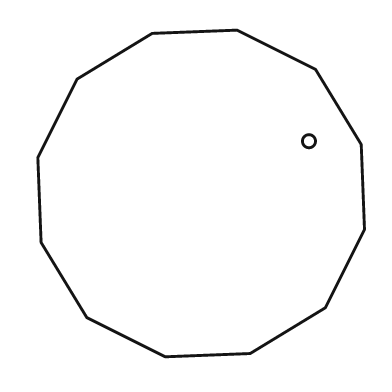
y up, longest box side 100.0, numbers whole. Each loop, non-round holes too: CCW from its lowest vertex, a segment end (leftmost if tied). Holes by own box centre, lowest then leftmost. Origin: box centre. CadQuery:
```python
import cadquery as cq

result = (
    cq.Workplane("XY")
    .moveTo(-11.0, -50.0)
    .lineTo(15.0, -49.0)
    .lineTo(38.0, -35.0)
    .lineTo(50.0, -11.0)
    .lineTo(49.0, 15.0)
    .lineTo(35.0, 38.0)
    .lineTo(11.0, 50.0)
    .lineTo(-15.0, 49.0)
    .lineTo(-38.0, 35.0)
    .lineTo(-50.0, 11.0)
    .lineTo(-49.0, -15.0)
    .lineTo(-35.0, -38.0)
    .close()
    .moveTo(33.0, 16.0)
    .circle(2.0)
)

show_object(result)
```